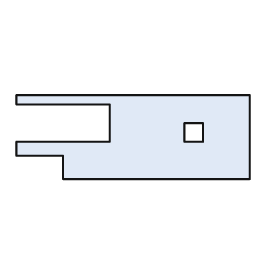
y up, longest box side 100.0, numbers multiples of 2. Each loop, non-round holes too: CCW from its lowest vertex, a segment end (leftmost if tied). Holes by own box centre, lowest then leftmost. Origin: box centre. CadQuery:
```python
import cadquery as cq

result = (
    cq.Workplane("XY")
    .moveTo(-30.0, -18.0)
    .lineTo(50.0, -18.0)
    .lineTo(50.0, 18.0)
    .lineTo(-50.0, 18.0)
    .lineTo(-50.0, 14.0)
    .lineTo(-10.0, 14.0)
    .lineTo(-10.0, -2.0)
    .lineTo(-50.0, -2.0)
    .lineTo(-50.0, -8.0)
    .lineTo(-30.0, -8.0)
    .close()
    .moveTo(22.0, -2.0)
    .lineTo(30.0, -2.0)
    .lineTo(30.0, 6.0)
    .lineTo(22.0, 6.0)
    .close()
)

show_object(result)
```